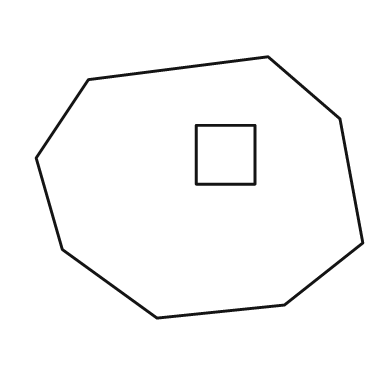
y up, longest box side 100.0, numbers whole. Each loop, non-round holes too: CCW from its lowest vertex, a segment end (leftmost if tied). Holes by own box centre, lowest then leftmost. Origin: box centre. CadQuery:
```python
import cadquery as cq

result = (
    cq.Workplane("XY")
    .moveTo(-13.0, -40.0)
    .lineTo(26.0, -36.0)
    .lineTo(50.0, -17.0)
    .lineTo(43.0, 21.0)
    .lineTo(21.0, 40.0)
    .lineTo(-34.0, 33.0)
    .lineTo(-50.0, 9.0)
    .lineTo(-42.0, -19.0)
    .close()
    .moveTo(-1.0, 1.0)
    .lineTo(17.0, 1.0)
    .lineTo(17.0, 19.0)
    .lineTo(-1.0, 19.0)
    .close()
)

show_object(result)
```